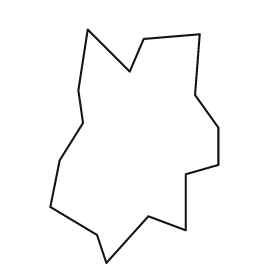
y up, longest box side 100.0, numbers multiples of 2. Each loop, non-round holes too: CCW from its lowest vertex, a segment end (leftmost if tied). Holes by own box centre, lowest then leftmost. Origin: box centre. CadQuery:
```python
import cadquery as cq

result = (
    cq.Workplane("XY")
    .moveTo(-12.0, -50.0)
    .lineTo(6.0, -30.0)
    .lineTo(22.0, -36.0)
    .lineTo(22.0, -12.0)
    .lineTo(36.0, -8.0)
    .lineTo(36.0, 8.0)
    .lineTo(26.0, 22.0)
    .lineTo(28.0, 48.0)
    .lineTo(4.0, 46.0)
    .lineTo(-2.0, 32.0)
    .lineTo(-20.0, 50.0)
    .lineTo(-24.0, 24.0)
    .lineTo(-22.0, 10.0)
    .lineTo(-32.0, -6.0)
    .lineTo(-36.0, -26.0)
    .lineTo(-16.0, -38.0)
    .close()
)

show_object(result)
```